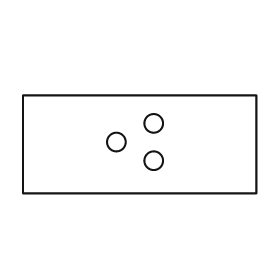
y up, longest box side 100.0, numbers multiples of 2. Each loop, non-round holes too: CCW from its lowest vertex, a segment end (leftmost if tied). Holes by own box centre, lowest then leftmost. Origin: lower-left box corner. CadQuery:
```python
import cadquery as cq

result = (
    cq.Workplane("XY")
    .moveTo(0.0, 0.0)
    .lineTo(100.0, 0.0)
    .lineTo(100.0, 42.0)
    .lineTo(0.0, 42.0)
    .close()
    .moveTo(56.0, 14.0)
    .circle(4.0)
    .moveTo(40.0, 22.0)
    .circle(4.0)
    .moveTo(56.0, 30.0)
    .circle(4.0)
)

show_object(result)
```